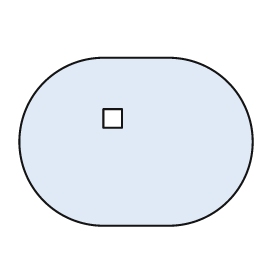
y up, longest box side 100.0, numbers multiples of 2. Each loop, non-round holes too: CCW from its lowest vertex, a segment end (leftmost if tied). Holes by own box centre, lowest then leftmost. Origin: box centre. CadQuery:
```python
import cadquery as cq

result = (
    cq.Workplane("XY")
    .moveTo(-14.0, -36.0)
    .lineTo(14.0, -36.0)
    .threePointArc((50.0, 0.0), (14.0, 36.0))
    .lineTo(-14.0, 36.0)
    .threePointArc((-50.0, 0.0), (-14.0, -36.0))
    .close()
    .moveTo(-14.0, 6.0)
    .lineTo(-6.0, 6.0)
    .lineTo(-6.0, 14.0)
    .lineTo(-14.0, 14.0)
    .close()
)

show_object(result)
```